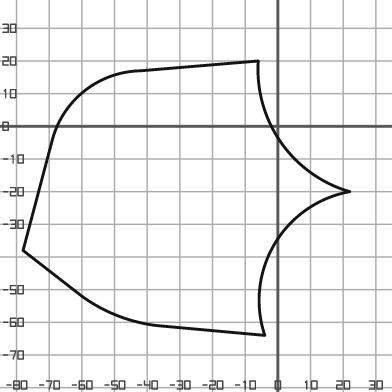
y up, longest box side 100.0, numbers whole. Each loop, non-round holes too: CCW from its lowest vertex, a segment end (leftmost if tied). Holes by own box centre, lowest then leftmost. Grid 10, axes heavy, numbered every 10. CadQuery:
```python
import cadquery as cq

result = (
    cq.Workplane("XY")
    .moveTo(-4.0, -64.0)
    .threePointArc((-1.0, -36.0), (22.0, -20.0))
    .threePointArc((1.0, -5.0), (-6.0, 20.0))
    .lineTo(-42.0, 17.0)
    .threePointArc((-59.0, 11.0), (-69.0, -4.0))
    .lineTo(-78.0, -38.0)
    .lineTo(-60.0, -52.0)
    .threePointArc((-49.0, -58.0), (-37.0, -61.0))
    .close()
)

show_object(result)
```